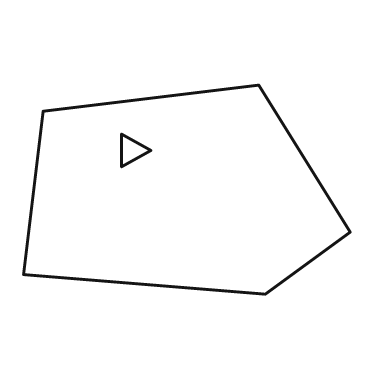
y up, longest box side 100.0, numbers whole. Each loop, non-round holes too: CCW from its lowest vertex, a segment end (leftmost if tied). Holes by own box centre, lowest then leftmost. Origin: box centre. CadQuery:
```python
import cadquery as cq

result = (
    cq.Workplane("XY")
    .moveTo(24.0, -32.0)
    .lineTo(50.0, -13.0)
    .lineTo(22.0, 32.0)
    .lineTo(-44.0, 24.0)
    .lineTo(-50.0, -26.0)
    .close()
    .moveTo(-20.0, 7.0)
    .lineTo(-11.0, 12.0)
    .lineTo(-20.0, 17.0)
    .close()
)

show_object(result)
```